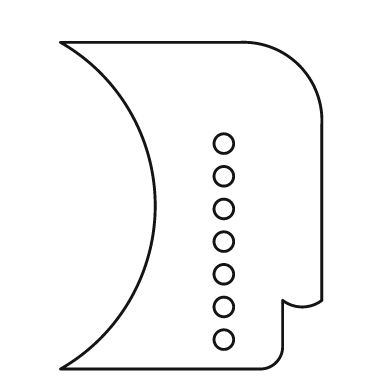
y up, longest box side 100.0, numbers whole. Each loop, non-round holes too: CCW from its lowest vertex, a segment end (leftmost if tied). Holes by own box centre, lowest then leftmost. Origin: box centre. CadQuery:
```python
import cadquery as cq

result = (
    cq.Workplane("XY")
    .moveTo(-40.0, -50.0)
    .lineTo(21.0, -50.0)
    .threePointArc((26.0, -48.0), (28.0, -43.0))
    .lineTo(28.0, -29.0)
    .threePointArc((34.0, -31.0), (40.0, -29.0))
    .lineTo(40.0, 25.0)
    .threePointArc((33.0, 43.0), (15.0, 50.0))
    .lineTo(-40.0, 50.0)
    .threePointArc((-11.0, 0.0), (-40.0, -50.0))
    .close()
    .moveTo(10.0, -41.0)
    .circle(3.0)
    .moveTo(10.0, -31.0)
    .circle(3.0)
    .moveTo(10.0, -21.0)
    .circle(3.0)
    .moveTo(10.0, -11.0)
    .circle(3.0)
    .moveTo(10.0, -1.0)
    .circle(3.0)
    .moveTo(10.0, 9.0)
    .circle(3.0)
    .moveTo(10.0, 19.0)
    .circle(3.0)
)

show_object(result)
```